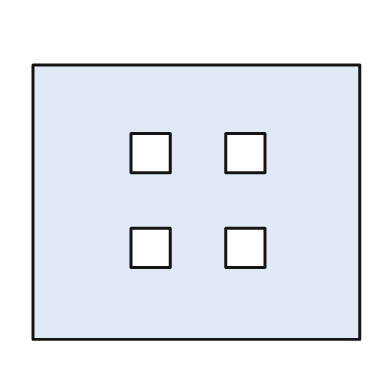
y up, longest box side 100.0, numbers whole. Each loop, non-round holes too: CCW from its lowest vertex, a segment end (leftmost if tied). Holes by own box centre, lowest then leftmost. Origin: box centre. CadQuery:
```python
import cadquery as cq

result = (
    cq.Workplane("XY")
    .moveTo(-50.0, -42.0)
    .lineTo(50.0, -42.0)
    .lineTo(50.0, 42.0)
    .lineTo(-50.0, 42.0)
    .close()
    .moveTo(-20.0, -20.0)
    .lineTo(-8.0, -20.0)
    .lineTo(-8.0, -8.0)
    .lineTo(-20.0, -8.0)
    .close()
    .moveTo(9.0, -20.0)
    .lineTo(21.0, -20.0)
    .lineTo(21.0, -8.0)
    .lineTo(9.0, -8.0)
    .close()
    .moveTo(-20.0, 9.0)
    .lineTo(-8.0, 9.0)
    .lineTo(-8.0, 21.0)
    .lineTo(-20.0, 21.0)
    .close()
    .moveTo(9.0, 9.0)
    .lineTo(21.0, 9.0)
    .lineTo(21.0, 21.0)
    .lineTo(9.0, 21.0)
    .close()
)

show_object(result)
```